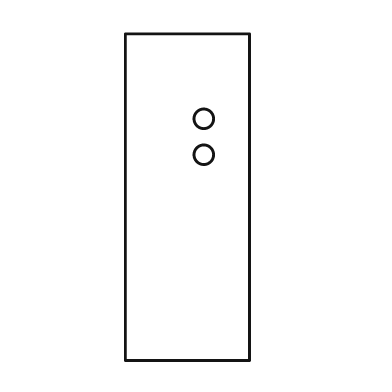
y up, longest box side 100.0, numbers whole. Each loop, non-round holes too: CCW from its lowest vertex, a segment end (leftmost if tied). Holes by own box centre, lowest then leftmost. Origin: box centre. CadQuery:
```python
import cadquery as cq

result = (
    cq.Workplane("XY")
    .moveTo(-19.0, -50.0)
    .lineTo(19.0, -50.0)
    .lineTo(19.0, 50.0)
    .lineTo(-19.0, 50.0)
    .close()
    .moveTo(5.0, 13.0)
    .circle(3.0)
    .moveTo(5.0, 24.0)
    .circle(3.0)
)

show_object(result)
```